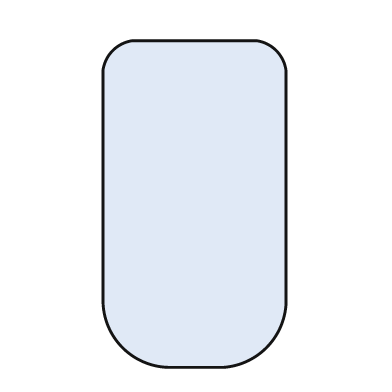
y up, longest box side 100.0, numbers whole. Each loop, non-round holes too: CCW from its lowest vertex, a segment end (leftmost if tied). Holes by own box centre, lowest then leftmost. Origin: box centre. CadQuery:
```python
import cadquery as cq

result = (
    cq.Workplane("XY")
    .moveTo(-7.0, -50.0)
    .lineTo(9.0, -50.0)
    .threePointArc((22.0, -44.0), (28.0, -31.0))
    .lineTo(28.0, 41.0)
    .threePointArc((25.0, 47.0), (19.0, 50.0))
    .lineTo(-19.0, 50.0)
    .threePointArc((-25.0, 47.0), (-28.0, 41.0))
    .lineTo(-28.0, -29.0)
    .threePointArc((-22.0, -44.0), (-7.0, -50.0))
    .close()
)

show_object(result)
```